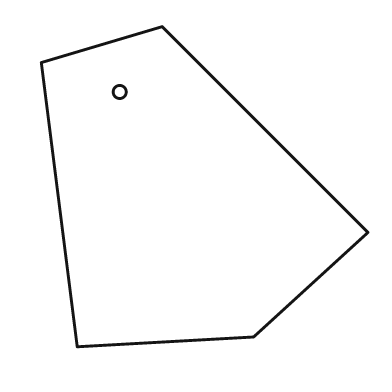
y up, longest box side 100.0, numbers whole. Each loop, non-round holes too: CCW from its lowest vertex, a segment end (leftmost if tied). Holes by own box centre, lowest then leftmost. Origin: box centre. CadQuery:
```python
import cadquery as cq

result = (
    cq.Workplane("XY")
    .moveTo(-39.0, -49.0)
    .lineTo(15.0, -46.0)
    .lineTo(50.0, -14.0)
    .lineTo(-13.0, 49.0)
    .lineTo(-50.0, 38.0)
    .close()
    .moveTo(-26.0, 29.0)
    .circle(2.0)
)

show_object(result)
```